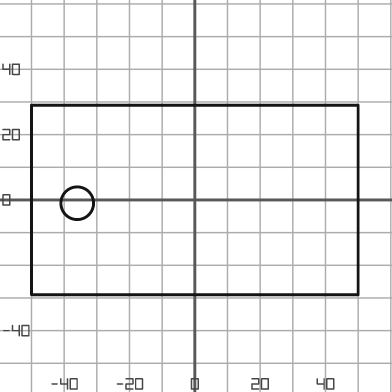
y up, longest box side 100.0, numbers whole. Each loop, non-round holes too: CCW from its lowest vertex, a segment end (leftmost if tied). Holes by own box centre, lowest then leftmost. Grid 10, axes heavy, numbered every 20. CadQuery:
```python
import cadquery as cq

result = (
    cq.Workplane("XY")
    .moveTo(-50.0, -29.0)
    .lineTo(50.0, -29.0)
    .lineTo(50.0, 29.0)
    .lineTo(-50.0, 29.0)
    .close()
    .moveTo(-36.0, -1.0)
    .circle(5.0)
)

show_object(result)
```